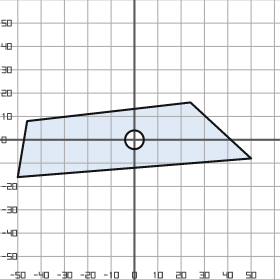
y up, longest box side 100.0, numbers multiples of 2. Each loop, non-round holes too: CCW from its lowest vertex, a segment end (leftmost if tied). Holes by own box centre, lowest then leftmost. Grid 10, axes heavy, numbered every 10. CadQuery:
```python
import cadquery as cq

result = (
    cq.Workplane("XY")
    .moveTo(-50.0, -16.0)
    .lineTo(50.0, -8.0)
    .lineTo(24.0, 16.0)
    .lineTo(-46.0, 8.0)
    .close()
    .moveTo(0.0, 0.0)
    .circle(4.0)
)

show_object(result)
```